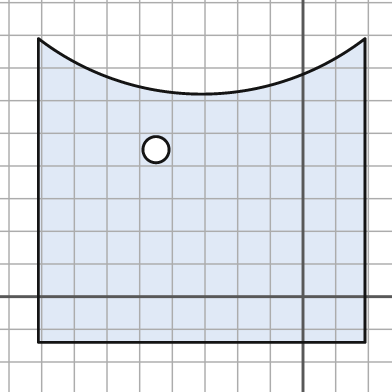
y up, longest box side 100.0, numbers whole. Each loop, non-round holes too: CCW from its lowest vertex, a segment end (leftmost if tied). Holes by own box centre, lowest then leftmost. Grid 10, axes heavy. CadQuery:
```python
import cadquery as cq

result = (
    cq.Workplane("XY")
    .moveTo(-81.0, -14.0)
    .lineTo(19.0, -14.0)
    .lineTo(19.0, 79.0)
    .threePointArc((-31.0, 62.0), (-81.0, 79.0))
    .close()
    .moveTo(-45.0, 45.0)
    .circle(4.0)
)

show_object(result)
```